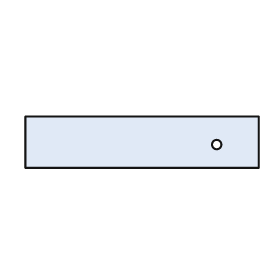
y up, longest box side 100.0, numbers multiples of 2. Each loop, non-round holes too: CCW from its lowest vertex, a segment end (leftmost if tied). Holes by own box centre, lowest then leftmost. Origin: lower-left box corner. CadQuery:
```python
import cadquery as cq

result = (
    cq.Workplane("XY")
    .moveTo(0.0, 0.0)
    .lineTo(100.0, 0.0)
    .lineTo(100.0, 22.0)
    .lineTo(0.0, 22.0)
    .close()
    .moveTo(82.0, 10.0)
    .circle(2.0)
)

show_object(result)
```